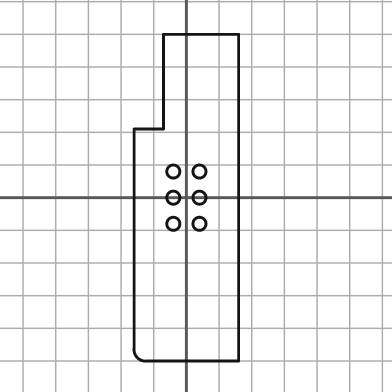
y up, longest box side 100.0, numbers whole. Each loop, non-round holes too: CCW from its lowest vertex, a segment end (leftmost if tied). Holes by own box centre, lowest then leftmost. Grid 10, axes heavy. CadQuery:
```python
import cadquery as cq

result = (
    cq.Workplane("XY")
    .moveTo(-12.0, -50.0)
    .lineTo(16.0, -50.0)
    .lineTo(16.0, 50.0)
    .lineTo(-7.0, 50.0)
    .lineTo(-7.0, 21.0)
    .lineTo(-16.0, 21.0)
    .lineTo(-16.0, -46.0)
    .threePointArc((-15.0, -49.0), (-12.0, -50.0))
    .close()
    .moveTo(-4.0, -8.0)
    .circle(2.0)
    .moveTo(4.0, -8.0)
    .circle(2.0)
    .moveTo(-4.0, 0.0)
    .circle(2.0)
    .moveTo(4.0, 0.0)
    .circle(2.0)
    .moveTo(-4.0, 8.0)
    .circle(2.0)
    .moveTo(4.0, 8.0)
    .circle(2.0)
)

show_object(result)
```